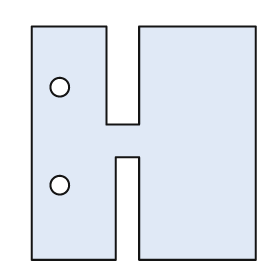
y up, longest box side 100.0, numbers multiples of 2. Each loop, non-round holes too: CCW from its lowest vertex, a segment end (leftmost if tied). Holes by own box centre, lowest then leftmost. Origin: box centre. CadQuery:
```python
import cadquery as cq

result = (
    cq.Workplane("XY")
    .moveTo(-48.0, -50.0)
    .lineTo(-12.0, -50.0)
    .lineTo(-12.0, -6.0)
    .lineTo(-2.0, -6.0)
    .lineTo(-2.0, -50.0)
    .lineTo(48.0, -50.0)
    .lineTo(48.0, 50.0)
    .lineTo(-2.0, 50.0)
    .lineTo(-2.0, 8.0)
    .lineTo(-16.0, 8.0)
    .lineTo(-16.0, 50.0)
    .lineTo(-48.0, 50.0)
    .close()
    .moveTo(-36.0, -18.0)
    .circle(4.0)
    .moveTo(-36.0, 24.0)
    .circle(4.0)
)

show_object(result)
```